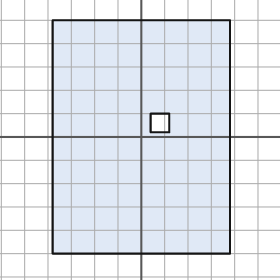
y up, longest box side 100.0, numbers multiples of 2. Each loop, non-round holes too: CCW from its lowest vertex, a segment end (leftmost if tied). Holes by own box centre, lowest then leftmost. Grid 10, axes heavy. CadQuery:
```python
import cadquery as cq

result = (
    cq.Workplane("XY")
    .moveTo(-38.0, -50.0)
    .lineTo(38.0, -50.0)
    .lineTo(38.0, 50.0)
    .lineTo(-38.0, 50.0)
    .close()
    .moveTo(4.0, 2.0)
    .lineTo(12.0, 2.0)
    .lineTo(12.0, 10.0)
    .lineTo(4.0, 10.0)
    .close()
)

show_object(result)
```